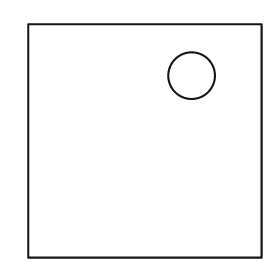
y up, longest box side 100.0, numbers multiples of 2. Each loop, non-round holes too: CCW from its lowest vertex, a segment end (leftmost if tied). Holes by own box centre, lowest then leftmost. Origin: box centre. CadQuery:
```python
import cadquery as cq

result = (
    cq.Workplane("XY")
    .moveTo(-50.0, -50.0)
    .lineTo(50.0, -50.0)
    .lineTo(50.0, 50.0)
    .lineTo(-50.0, 50.0)
    .close()
    .moveTo(20.0, 28.0)
    .circle(10.0)
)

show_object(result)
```